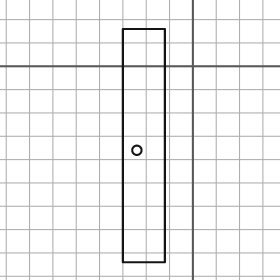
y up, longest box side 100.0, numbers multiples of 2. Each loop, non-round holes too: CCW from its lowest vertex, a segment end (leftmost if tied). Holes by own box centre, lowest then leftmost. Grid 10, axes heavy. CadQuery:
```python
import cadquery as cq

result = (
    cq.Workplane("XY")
    .moveTo(-30.0, -84.0)
    .lineTo(-12.0, -84.0)
    .lineTo(-12.0, 16.0)
    .lineTo(-30.0, 16.0)
    .close()
    .moveTo(-24.0, -36.0)
    .circle(2.0)
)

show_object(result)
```